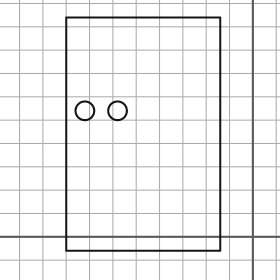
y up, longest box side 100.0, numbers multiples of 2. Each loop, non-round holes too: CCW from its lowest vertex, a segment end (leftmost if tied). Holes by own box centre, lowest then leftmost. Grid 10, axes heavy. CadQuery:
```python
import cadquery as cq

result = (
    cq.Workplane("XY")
    .moveTo(-80.0, -6.0)
    .lineTo(-14.0, -6.0)
    .lineTo(-14.0, 94.0)
    .lineTo(-80.0, 94.0)
    .close()
    .moveTo(-72.0, 54.0)
    .circle(4.0)
    .moveTo(-58.0, 54.0)
    .circle(4.0)
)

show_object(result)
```